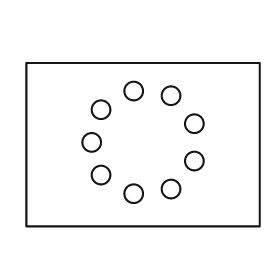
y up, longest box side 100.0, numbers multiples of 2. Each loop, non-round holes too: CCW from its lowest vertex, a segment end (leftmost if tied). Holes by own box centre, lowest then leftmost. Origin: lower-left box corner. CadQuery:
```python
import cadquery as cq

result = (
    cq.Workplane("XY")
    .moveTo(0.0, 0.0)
    .lineTo(100.0, 0.0)
    .lineTo(100.0, 70.0)
    .lineTo(0.0, 70.0)
    .close()
    .moveTo(46.0, 14.0)
    .circle(4.0)
    .moveTo(62.0, 16.0)
    .circle(4.0)
    .moveTo(32.0, 22.0)
    .circle(4.0)
    .moveTo(72.0, 28.0)
    .circle(4.0)
    .moveTo(28.0, 36.0)
    .circle(4.0)
    .moveTo(72.0, 44.0)
    .circle(4.0)
    .moveTo(32.0, 50.0)
    .circle(4.0)
    .moveTo(62.0, 56.0)
    .circle(4.0)
    .moveTo(46.0, 58.0)
    .circle(4.0)
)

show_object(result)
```